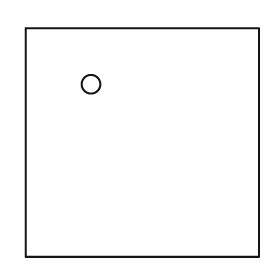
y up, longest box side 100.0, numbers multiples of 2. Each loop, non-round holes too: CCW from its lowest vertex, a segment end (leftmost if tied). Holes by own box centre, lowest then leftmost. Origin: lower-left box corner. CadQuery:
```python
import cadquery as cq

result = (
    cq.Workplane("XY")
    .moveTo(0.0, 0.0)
    .lineTo(100.0, 0.0)
    .lineTo(100.0, 98.0)
    .lineTo(0.0, 98.0)
    .close()
    .moveTo(28.0, 74.0)
    .circle(4.0)
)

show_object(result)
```